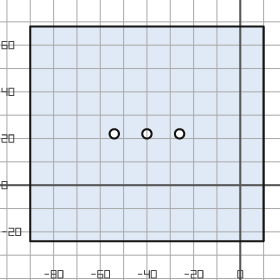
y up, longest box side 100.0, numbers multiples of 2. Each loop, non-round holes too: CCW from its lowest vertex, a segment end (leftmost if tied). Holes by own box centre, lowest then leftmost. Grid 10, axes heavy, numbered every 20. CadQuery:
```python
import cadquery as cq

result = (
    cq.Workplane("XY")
    .moveTo(-90.0, -24.0)
    .lineTo(10.0, -24.0)
    .lineTo(10.0, 68.0)
    .lineTo(-90.0, 68.0)
    .close()
    .moveTo(-54.0, 22.0)
    .circle(2.0)
    .moveTo(-40.0, 22.0)
    .circle(2.0)
    .moveTo(-26.0, 22.0)
    .circle(2.0)
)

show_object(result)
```